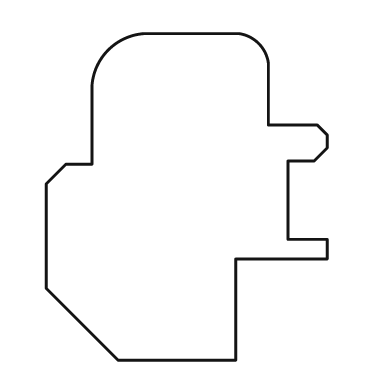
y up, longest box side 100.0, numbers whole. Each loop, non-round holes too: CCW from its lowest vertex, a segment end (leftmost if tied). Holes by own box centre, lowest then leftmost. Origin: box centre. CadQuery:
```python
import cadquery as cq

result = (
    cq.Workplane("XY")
    .moveTo(-21.0, -50.0)
    .lineTo(15.0, -50.0)
    .lineTo(15.0, -19.0)
    .lineTo(43.0, -19.0)
    .lineTo(43.0, -13.0)
    .lineTo(31.0, -13.0)
    .lineTo(31.0, 11.0)
    .lineTo(39.0, 11.0)
    .lineTo(43.0, 15.0)
    .lineTo(43.0, 19.0)
    .lineTo(40.0, 22.0)
    .lineTo(25.0, 22.0)
    .lineTo(25.0, 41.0)
    .threePointArc((22.0, 47.0), (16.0, 50.0))
    .lineTo(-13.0, 50.0)
    .threePointArc((-24.0, 45.0), (-29.0, 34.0))
    .lineTo(-29.0, 10.0)
    .lineTo(-37.0, 10.0)
    .lineTo(-43.0, 4.0)
    .lineTo(-43.0, -28.0)
    .close()
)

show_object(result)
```